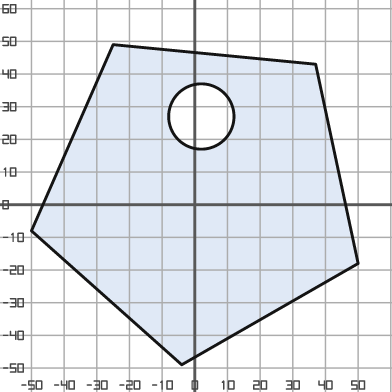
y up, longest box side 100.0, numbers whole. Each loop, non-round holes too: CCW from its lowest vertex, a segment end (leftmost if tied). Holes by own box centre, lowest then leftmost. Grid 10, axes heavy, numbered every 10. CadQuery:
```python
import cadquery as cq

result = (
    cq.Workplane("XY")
    .moveTo(-4.0, -49.0)
    .lineTo(50.0, -18.0)
    .lineTo(37.0, 43.0)
    .lineTo(-25.0, 49.0)
    .lineTo(-50.0, -8.0)
    .close()
    .moveTo(2.0, 27.0)
    .circle(10.0)
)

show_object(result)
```